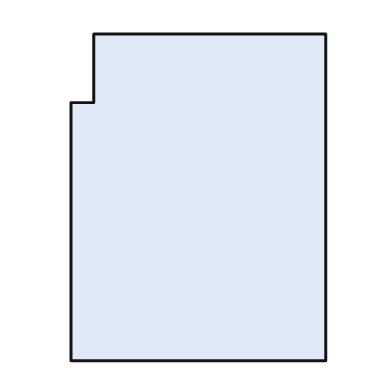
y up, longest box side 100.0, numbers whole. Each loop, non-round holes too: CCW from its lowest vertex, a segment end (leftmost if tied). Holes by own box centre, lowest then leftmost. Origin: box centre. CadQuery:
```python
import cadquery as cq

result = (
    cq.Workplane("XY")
    .moveTo(-39.0, -50.0)
    .lineTo(39.0, -50.0)
    .lineTo(39.0, 50.0)
    .lineTo(-32.0, 50.0)
    .lineTo(-32.0, 29.0)
    .lineTo(-39.0, 29.0)
    .close()
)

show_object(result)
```